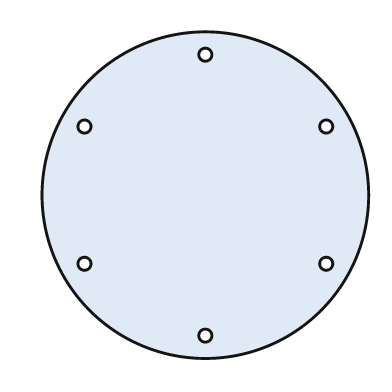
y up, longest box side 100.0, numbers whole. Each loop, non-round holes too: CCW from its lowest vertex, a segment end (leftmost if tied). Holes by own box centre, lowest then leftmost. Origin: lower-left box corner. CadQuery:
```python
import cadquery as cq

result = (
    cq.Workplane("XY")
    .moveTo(50.0, 50.0)
    .circle(50.0)
    .moveTo(50.0, 7.0)
    .circle(2.0)
    .moveTo(13.0, 29.0)
    .circle(2.0)
    .moveTo(87.0, 29.0)
    .circle(2.0)
    .moveTo(13.0, 71.0)
    .circle(2.0)
    .moveTo(87.0, 71.0)
    .circle(2.0)
    .moveTo(50.0, 93.0)
    .circle(2.0)
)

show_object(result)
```